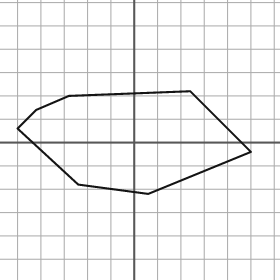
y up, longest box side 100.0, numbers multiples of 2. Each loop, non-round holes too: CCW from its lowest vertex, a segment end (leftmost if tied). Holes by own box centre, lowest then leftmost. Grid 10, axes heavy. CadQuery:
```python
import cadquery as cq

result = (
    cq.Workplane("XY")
    .moveTo(6.0, -22.0)
    .lineTo(50.0, -4.0)
    .lineTo(24.0, 22.0)
    .lineTo(-28.0, 20.0)
    .lineTo(-42.0, 14.0)
    .lineTo(-50.0, 6.0)
    .lineTo(-24.0, -18.0)
    .close()
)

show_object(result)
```